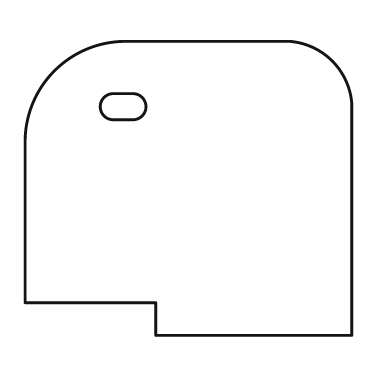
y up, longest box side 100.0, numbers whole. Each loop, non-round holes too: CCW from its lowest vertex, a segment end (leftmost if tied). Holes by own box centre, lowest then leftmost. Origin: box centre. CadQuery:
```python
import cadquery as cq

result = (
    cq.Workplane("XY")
    .moveTo(-10.0, -45.0)
    .lineTo(50.0, -45.0)
    .lineTo(50.0, 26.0)
    .threePointArc((44.0, 39.0), (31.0, 45.0))
    .lineTo(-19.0, 45.0)
    .threePointArc((-41.0, 36.0), (-50.0, 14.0))
    .lineTo(-50.0, -35.0)
    .lineTo(-10.0, -35.0)
    .close()
    .moveTo(-23.0, 21.0)
    .lineTo(-17.0, 21.0)
    .threePointArc((-13.0, 25.0), (-17.0, 29.0))
    .lineTo(-23.0, 29.0)
    .threePointArc((-27.0, 25.0), (-23.0, 21.0))
    .close()
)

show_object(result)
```